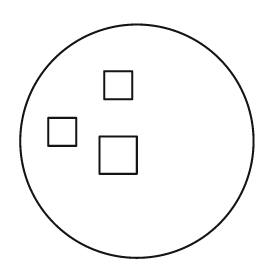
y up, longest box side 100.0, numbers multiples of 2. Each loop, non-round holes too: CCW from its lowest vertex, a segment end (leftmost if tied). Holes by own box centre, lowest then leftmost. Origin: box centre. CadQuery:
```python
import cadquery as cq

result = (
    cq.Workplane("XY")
    .moveTo(0.0, 0.0)
    .circle(50.0)
    .moveTo(-16.0, -14.0)
    .lineTo(0.0, -14.0)
    .lineTo(0.0, 2.0)
    .lineTo(-16.0, 2.0)
    .close()
    .moveTo(-38.0, -2.0)
    .lineTo(-26.0, -2.0)
    .lineTo(-26.0, 10.0)
    .lineTo(-38.0, 10.0)
    .close()
    .moveTo(-14.0, 18.0)
    .lineTo(-2.0, 18.0)
    .lineTo(-2.0, 30.0)
    .lineTo(-14.0, 30.0)
    .close()
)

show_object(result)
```